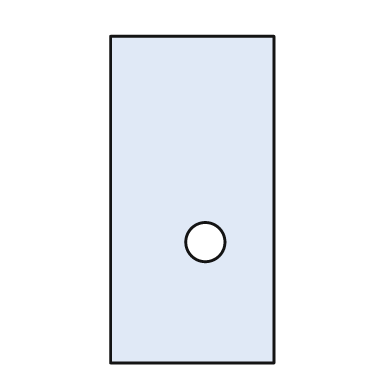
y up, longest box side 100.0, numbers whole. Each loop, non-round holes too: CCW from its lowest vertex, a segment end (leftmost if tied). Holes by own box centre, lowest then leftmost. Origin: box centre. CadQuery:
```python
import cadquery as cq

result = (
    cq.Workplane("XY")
    .moveTo(-25.0, -50.0)
    .lineTo(25.0, -50.0)
    .lineTo(25.0, 50.0)
    .lineTo(-25.0, 50.0)
    .close()
    .moveTo(4.0, -13.0)
    .circle(6.0)
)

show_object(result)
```